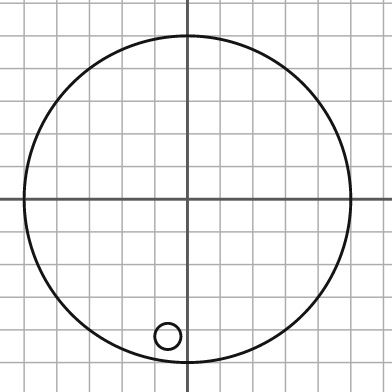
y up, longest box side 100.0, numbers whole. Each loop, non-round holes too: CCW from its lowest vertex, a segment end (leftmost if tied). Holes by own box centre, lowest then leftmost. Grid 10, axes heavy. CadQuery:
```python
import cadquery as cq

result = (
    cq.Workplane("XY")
    .moveTo(0.0, 0.0)
    .circle(50.0)
    .moveTo(-6.0, -42.0)
    .circle(4.0)
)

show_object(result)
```